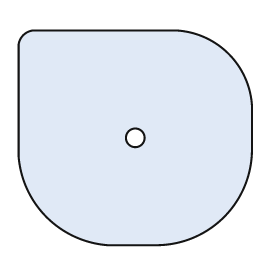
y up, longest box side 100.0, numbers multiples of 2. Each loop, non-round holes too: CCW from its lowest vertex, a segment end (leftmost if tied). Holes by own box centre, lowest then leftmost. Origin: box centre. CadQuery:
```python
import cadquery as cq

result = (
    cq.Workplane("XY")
    .moveTo(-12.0, -46.0)
    .lineTo(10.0, -46.0)
    .threePointArc((38.0, -34.0), (50.0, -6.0))
    .lineTo(50.0, 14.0)
    .threePointArc((40.0, 36.0), (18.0, 46.0))
    .lineTo(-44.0, 46.0)
    .threePointArc((-48.0, 44.0), (-50.0, 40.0))
    .lineTo(-50.0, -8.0)
    .threePointArc((-38.0, -34.0), (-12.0, -46.0))
    .close()
    .moveTo(0.0, 0.0)
    .circle(4.0)
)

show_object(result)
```